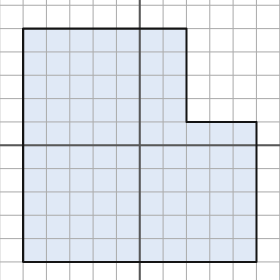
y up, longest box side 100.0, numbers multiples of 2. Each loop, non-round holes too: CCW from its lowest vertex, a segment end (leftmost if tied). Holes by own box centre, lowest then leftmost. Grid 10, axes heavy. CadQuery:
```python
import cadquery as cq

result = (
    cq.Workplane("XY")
    .moveTo(-50.0, -50.0)
    .lineTo(50.0, -50.0)
    .lineTo(50.0, 10.0)
    .lineTo(20.0, 10.0)
    .lineTo(20.0, 50.0)
    .lineTo(-50.0, 50.0)
    .close()
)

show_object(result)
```